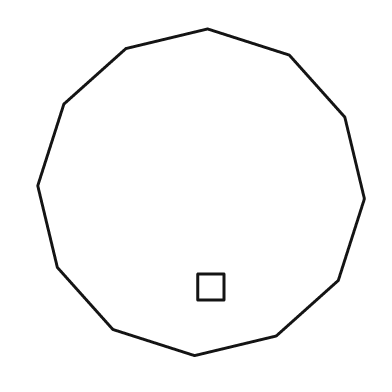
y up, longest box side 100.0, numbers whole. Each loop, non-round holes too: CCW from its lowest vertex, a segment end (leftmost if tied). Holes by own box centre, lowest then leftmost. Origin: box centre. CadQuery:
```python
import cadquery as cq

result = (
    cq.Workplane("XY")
    .moveTo(-2.0, -50.0)
    .lineTo(23.0, -44.0)
    .lineTo(42.0, -27.0)
    .lineTo(50.0, -2.0)
    .lineTo(44.0, 23.0)
    .lineTo(27.0, 42.0)
    .lineTo(2.0, 50.0)
    .lineTo(-23.0, 44.0)
    .lineTo(-42.0, 27.0)
    .lineTo(-50.0, 2.0)
    .lineTo(-44.0, -23.0)
    .lineTo(-27.0, -42.0)
    .close()
    .moveTo(-1.0, -33.0)
    .lineTo(7.0, -33.0)
    .lineTo(7.0, -25.0)
    .lineTo(-1.0, -25.0)
    .close()
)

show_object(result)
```